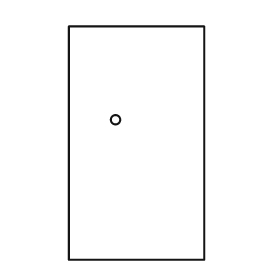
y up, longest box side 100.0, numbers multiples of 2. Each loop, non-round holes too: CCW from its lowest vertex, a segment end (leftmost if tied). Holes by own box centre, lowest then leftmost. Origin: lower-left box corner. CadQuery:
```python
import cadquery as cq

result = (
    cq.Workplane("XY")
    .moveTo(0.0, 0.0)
    .lineTo(58.0, 0.0)
    .lineTo(58.0, 100.0)
    .lineTo(0.0, 100.0)
    .close()
    .moveTo(20.0, 60.0)
    .circle(2.0)
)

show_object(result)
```